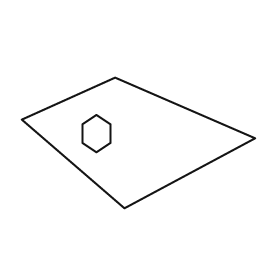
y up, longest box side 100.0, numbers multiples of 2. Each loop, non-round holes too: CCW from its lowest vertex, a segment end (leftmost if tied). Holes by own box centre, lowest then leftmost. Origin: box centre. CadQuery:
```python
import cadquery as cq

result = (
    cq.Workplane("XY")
    .moveTo(-6.0, -28.0)
    .lineTo(50.0, 2.0)
    .lineTo(-10.0, 28.0)
    .lineTo(-50.0, 10.0)
    .close()
    .moveTo(-18.0, -4.0)
    .lineTo(-12.0, 0.0)
    .lineTo(-12.0, 8.0)
    .lineTo(-18.0, 12.0)
    .lineTo(-24.0, 8.0)
    .lineTo(-24.0, 0.0)
    .close()
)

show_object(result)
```